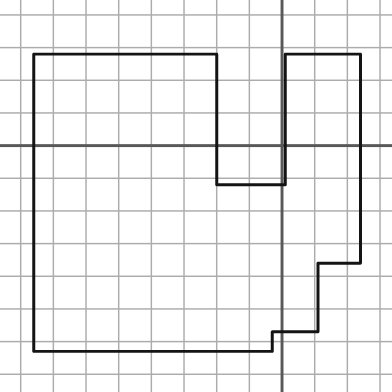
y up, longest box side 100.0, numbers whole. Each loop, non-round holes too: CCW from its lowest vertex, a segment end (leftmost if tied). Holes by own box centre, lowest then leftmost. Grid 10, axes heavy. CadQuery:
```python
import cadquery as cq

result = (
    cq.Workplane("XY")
    .moveTo(-76.0, -63.0)
    .lineTo(-3.0, -63.0)
    .lineTo(-3.0, -57.0)
    .lineTo(11.0, -57.0)
    .lineTo(11.0, -36.0)
    .lineTo(24.0, -36.0)
    .lineTo(24.0, 28.0)
    .lineTo(1.0, 28.0)
    .lineTo(1.0, -12.0)
    .lineTo(-20.0, -12.0)
    .lineTo(-20.0, 28.0)
    .lineTo(-76.0, 28.0)
    .close()
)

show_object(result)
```